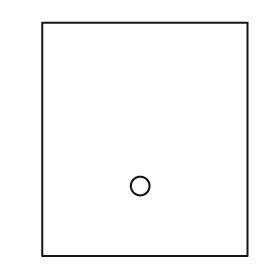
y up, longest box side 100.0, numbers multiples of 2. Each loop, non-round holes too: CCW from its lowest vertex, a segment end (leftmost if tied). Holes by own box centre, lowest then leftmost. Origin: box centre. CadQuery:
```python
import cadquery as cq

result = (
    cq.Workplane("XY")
    .moveTo(-44.0, -50.0)
    .lineTo(44.0, -50.0)
    .lineTo(44.0, 50.0)
    .lineTo(-44.0, 50.0)
    .close()
    .moveTo(-2.0, -20.0)
    .circle(4.0)
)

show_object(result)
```